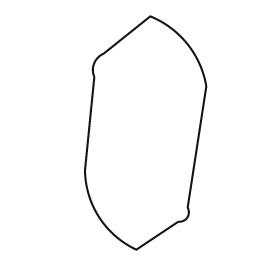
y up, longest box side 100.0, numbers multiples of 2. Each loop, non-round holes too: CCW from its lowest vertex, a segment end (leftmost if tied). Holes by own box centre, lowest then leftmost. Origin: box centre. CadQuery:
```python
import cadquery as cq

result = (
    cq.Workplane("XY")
    .moveTo(-4.0, -50.0)
    .lineTo(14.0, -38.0)
    .threePointArc((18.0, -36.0), (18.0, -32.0))
    .lineTo(26.0, 20.0)
    .threePointArc((18.0, 38.0), (2.0, 50.0))
    .lineTo(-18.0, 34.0)
    .threePointArc((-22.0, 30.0), (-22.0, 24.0))
    .lineTo(-26.0, -16.0)
    .threePointArc((-20.0, -36.0), (-4.0, -50.0))
    .close()
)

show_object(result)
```